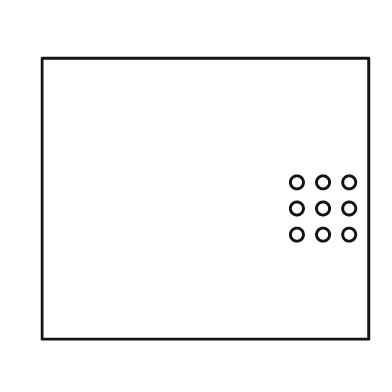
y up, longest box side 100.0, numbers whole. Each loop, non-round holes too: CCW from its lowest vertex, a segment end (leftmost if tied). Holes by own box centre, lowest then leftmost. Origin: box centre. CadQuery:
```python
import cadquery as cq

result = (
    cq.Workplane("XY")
    .moveTo(-50.0, -43.0)
    .lineTo(50.0, -43.0)
    .lineTo(50.0, 43.0)
    .lineTo(-50.0, 43.0)
    .close()
    .moveTo(28.0, -11.0)
    .circle(2.0)
    .moveTo(36.0, -11.0)
    .circle(2.0)
    .moveTo(44.0, -11.0)
    .circle(2.0)
    .moveTo(28.0, -3.0)
    .circle(2.0)
    .moveTo(36.0, -3.0)
    .circle(2.0)
    .moveTo(44.0, -3.0)
    .circle(2.0)
    .moveTo(28.0, 5.0)
    .circle(2.0)
    .moveTo(36.0, 5.0)
    .circle(2.0)
    .moveTo(44.0, 5.0)
    .circle(2.0)
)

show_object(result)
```